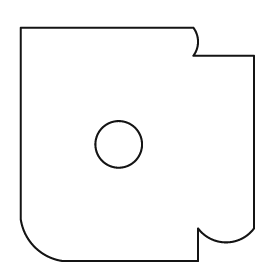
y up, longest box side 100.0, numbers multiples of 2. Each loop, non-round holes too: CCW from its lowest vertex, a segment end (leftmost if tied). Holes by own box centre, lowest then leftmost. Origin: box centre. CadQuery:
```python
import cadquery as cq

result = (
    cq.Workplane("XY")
    .moveTo(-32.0, -50.0)
    .lineTo(26.0, -50.0)
    .lineTo(26.0, -36.0)
    .threePointArc((38.0, -42.0), (50.0, -36.0))
    .lineTo(50.0, 38.0)
    .lineTo(24.0, 38.0)
    .threePointArc((26.0, 44.0), (24.0, 50.0))
    .lineTo(-50.0, 50.0)
    .lineTo(-50.0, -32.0)
    .threePointArc((-44.0, -44.0), (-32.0, -50.0))
    .close()
    .moveTo(-8.0, 0.0)
    .circle(10.0)
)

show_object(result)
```